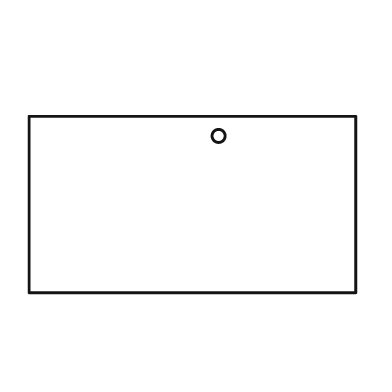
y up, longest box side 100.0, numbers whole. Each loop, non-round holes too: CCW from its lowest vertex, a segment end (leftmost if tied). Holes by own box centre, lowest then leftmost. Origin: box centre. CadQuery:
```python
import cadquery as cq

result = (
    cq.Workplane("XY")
    .moveTo(-50.0, -27.0)
    .lineTo(50.0, -27.0)
    .lineTo(50.0, 27.0)
    .lineTo(-50.0, 27.0)
    .close()
    .moveTo(8.0, 21.0)
    .circle(2.0)
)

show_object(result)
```